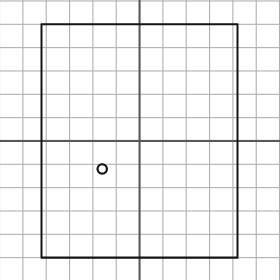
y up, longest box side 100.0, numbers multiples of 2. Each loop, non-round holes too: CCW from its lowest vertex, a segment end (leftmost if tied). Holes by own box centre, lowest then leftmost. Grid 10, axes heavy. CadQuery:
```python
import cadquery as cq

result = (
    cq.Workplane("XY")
    .moveTo(-42.0, -50.0)
    .lineTo(42.0, -50.0)
    .lineTo(42.0, 50.0)
    .lineTo(-42.0, 50.0)
    .close()
    .moveTo(-16.0, -12.0)
    .circle(2.0)
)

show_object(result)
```